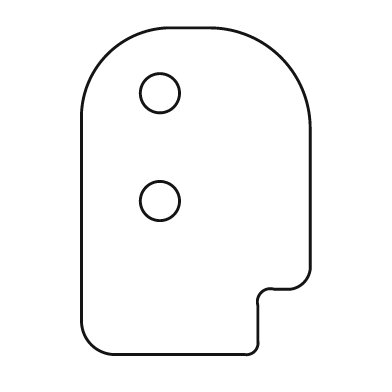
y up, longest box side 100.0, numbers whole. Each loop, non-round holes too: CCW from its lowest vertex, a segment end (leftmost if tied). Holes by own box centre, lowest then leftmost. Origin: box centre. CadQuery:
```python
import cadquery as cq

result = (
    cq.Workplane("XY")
    .moveTo(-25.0, -50.0)
    .lineTo(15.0, -50.0)
    .threePointArc((18.0, -49.0), (19.0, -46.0))
    .lineTo(19.0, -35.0)
    .threePointArc((20.0, -31.0), (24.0, -30.0))
    .lineTo(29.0, -30.0)
    .threePointArc((33.0, -28.0), (35.0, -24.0))
    .lineTo(35.0, 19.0)
    .threePointArc((26.0, 41.0), (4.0, 50.0))
    .lineTo(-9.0, 50.0)
    .threePointArc((-27.0, 42.0), (-35.0, 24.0))
    .lineTo(-35.0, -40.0)
    .threePointArc((-32.0, -47.0), (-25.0, -50.0))
    .close()
    .moveTo(-11.0, -3.0)
    .circle(6.0)
    .moveTo(-11.0, 30.0)
    .circle(6.0)
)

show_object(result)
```